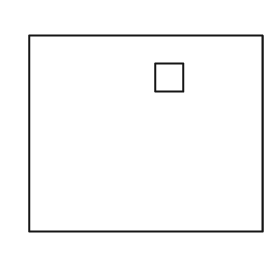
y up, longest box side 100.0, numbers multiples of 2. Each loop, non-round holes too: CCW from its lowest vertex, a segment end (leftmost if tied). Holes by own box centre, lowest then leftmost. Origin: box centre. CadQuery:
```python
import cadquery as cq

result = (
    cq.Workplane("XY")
    .moveTo(-50.0, -42.0)
    .lineTo(50.0, -42.0)
    .lineTo(50.0, 42.0)
    .lineTo(-50.0, 42.0)
    .close()
    .moveTo(4.0, 18.0)
    .lineTo(16.0, 18.0)
    .lineTo(16.0, 30.0)
    .lineTo(4.0, 30.0)
    .close()
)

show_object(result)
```